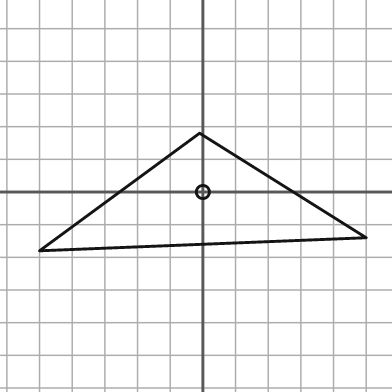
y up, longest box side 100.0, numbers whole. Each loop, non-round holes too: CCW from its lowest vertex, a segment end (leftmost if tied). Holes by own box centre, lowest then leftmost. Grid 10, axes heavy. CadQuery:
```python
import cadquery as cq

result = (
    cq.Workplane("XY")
    .moveTo(-50.0, -18.0)
    .lineTo(50.0, -14.0)
    .lineTo(-1.0, 18.0)
    .close()
    .moveTo(0.0, 0.0)
    .circle(2.0)
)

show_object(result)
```